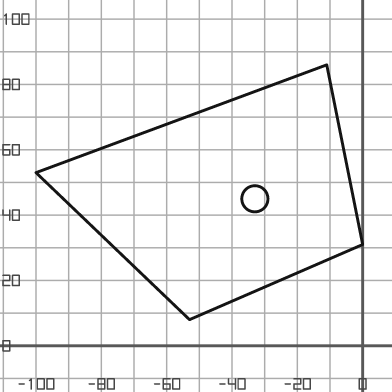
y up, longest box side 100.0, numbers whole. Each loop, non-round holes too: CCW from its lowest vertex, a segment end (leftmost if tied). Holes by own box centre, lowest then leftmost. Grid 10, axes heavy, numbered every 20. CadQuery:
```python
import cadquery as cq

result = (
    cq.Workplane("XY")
    .moveTo(-53.0, 8.0)
    .lineTo(0.0, 31.0)
    .lineTo(-11.0, 86.0)
    .lineTo(-100.0, 53.0)
    .close()
    .moveTo(-33.0, 45.0)
    .circle(4.0)
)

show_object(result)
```